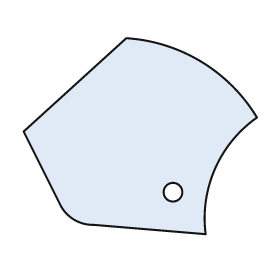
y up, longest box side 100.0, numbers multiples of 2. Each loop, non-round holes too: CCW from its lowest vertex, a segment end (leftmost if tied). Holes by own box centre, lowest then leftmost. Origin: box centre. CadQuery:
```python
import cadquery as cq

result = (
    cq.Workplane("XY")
    .moveTo(28.0, -42.0)
    .threePointArc((32.0, -14.0), (50.0, 8.0))
    .threePointArc((26.0, 32.0), (-6.0, 42.0))
    .lineTo(-50.0, 2.0)
    .lineTo(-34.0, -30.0)
    .threePointArc((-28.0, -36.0), (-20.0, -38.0))
    .close()
    .moveTo(14.0, -24.0)
    .circle(4.0)
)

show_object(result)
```